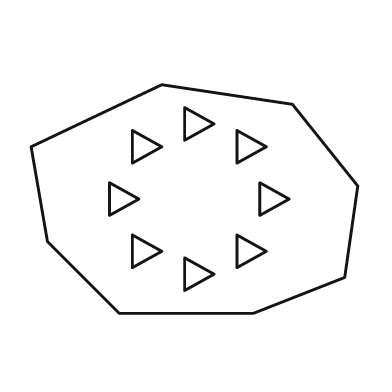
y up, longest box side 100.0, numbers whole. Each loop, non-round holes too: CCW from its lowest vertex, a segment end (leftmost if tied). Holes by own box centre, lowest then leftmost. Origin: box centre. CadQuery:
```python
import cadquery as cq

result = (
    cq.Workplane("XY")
    .moveTo(-23.0, -35.0)
    .lineTo(18.0, -35.0)
    .lineTo(46.0, -24.0)
    .lineTo(50.0, 4.0)
    .lineTo(30.0, 29.0)
    .lineTo(-10.0, 35.0)
    .lineTo(-50.0, 16.0)
    .lineTo(-45.0, -13.0)
    .close()
    .moveTo(-3.0, -28.0)
    .lineTo(6.0, -23.0)
    .lineTo(-3.0, -18.0)
    .close()
    .moveTo(-19.0, -21.0)
    .lineTo(-10.0, -16.0)
    .lineTo(-19.0, -11.0)
    .close()
    .moveTo(13.0, -21.0)
    .lineTo(22.0, -16.0)
    .lineTo(13.0, -11.0)
    .close()
    .moveTo(-26.0, -5.0)
    .lineTo(-17.0, 0.0)
    .lineTo(-26.0, 5.0)
    .close()
    .moveTo(20.0, -5.0)
    .lineTo(29.0, 0.0)
    .lineTo(20.0, 5.0)
    .close()
    .moveTo(-19.0, 11.0)
    .lineTo(-10.0, 16.0)
    .lineTo(-19.0, 21.0)
    .close()
    .moveTo(13.0, 11.0)
    .lineTo(22.0, 16.0)
    .lineTo(13.0, 21.0)
    .close()
    .moveTo(-3.0, 18.0)
    .lineTo(6.0, 23.0)
    .lineTo(-3.0, 28.0)
    .close()
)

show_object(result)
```